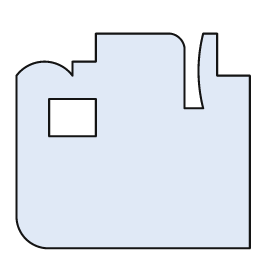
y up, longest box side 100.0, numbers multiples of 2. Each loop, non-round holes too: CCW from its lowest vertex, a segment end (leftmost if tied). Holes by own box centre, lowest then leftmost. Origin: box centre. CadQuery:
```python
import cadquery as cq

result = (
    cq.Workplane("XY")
    .moveTo(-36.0, -46.0)
    .lineTo(50.0, -46.0)
    .lineTo(50.0, 28.0)
    .lineTo(36.0, 28.0)
    .lineTo(36.0, 46.0)
    .lineTo(30.0, 46.0)
    .threePointArc((28.0, 30.0), (30.0, 14.0))
    .lineTo(22.0, 14.0)
    .lineTo(22.0, 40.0)
    .threePointArc((20.0, 44.0), (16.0, 46.0))
    .lineTo(-16.0, 46.0)
    .lineTo(-16.0, 34.0)
    .lineTo(-26.0, 34.0)
    .lineTo(-26.0, 28.0)
    .threePointArc((-38.0, 34.0), (-50.0, 28.0))
    .lineTo(-50.0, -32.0)
    .threePointArc((-46.0, -42.0), (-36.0, -46.0))
    .close()
    .moveTo(-36.0, 2.0)
    .lineTo(-16.0, 2.0)
    .lineTo(-16.0, 18.0)
    .lineTo(-36.0, 18.0)
    .close()
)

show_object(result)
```